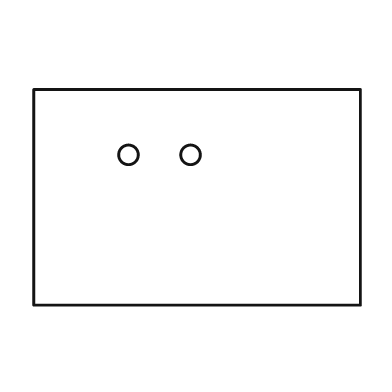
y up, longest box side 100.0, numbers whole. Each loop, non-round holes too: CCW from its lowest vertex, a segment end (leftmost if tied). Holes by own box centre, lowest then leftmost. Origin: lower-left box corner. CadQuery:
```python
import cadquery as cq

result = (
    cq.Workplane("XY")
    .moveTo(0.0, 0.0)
    .lineTo(100.0, 0.0)
    .lineTo(100.0, 66.0)
    .lineTo(0.0, 66.0)
    .close()
    .moveTo(29.0, 46.0)
    .circle(3.0)
    .moveTo(48.0, 46.0)
    .circle(3.0)
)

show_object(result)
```